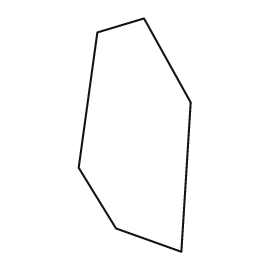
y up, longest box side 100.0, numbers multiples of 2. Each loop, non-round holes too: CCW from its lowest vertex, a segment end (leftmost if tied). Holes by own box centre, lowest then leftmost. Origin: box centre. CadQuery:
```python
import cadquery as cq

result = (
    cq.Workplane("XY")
    .moveTo(20.0, -50.0)
    .lineTo(24.0, 14.0)
    .lineTo(4.0, 50.0)
    .lineTo(-16.0, 44.0)
    .lineTo(-24.0, -14.0)
    .lineTo(-8.0, -40.0)
    .close()
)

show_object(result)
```